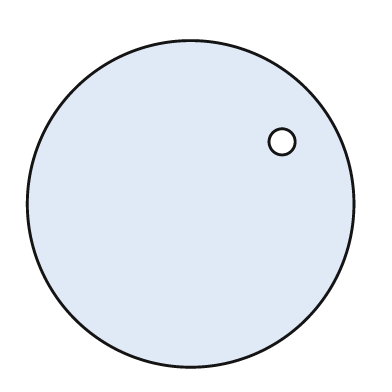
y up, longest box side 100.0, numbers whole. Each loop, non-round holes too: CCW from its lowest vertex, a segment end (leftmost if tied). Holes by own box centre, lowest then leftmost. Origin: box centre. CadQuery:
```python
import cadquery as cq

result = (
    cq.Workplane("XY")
    .moveTo(0.0, 0.0)
    .circle(50.0)
    .moveTo(28.0, 19.0)
    .circle(4.0)
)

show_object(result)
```